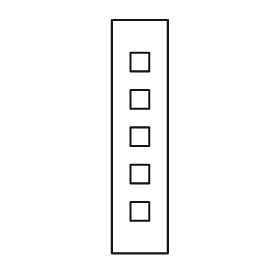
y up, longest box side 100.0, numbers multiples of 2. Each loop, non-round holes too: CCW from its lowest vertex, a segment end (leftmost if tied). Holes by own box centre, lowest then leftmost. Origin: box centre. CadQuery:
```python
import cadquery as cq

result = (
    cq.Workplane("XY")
    .moveTo(-12.0, -50.0)
    .lineTo(12.0, -50.0)
    .lineTo(12.0, 50.0)
    .lineTo(-12.0, 50.0)
    .close()
    .moveTo(-4.0, -36.0)
    .lineTo(4.0, -36.0)
    .lineTo(4.0, -28.0)
    .lineTo(-4.0, -28.0)
    .close()
    .moveTo(-4.0, -20.0)
    .lineTo(4.0, -20.0)
    .lineTo(4.0, -12.0)
    .lineTo(-4.0, -12.0)
    .close()
    .moveTo(-4.0, -4.0)
    .lineTo(4.0, -4.0)
    .lineTo(4.0, 4.0)
    .lineTo(-4.0, 4.0)
    .close()
    .moveTo(-4.0, 12.0)
    .lineTo(4.0, 12.0)
    .lineTo(4.0, 20.0)
    .lineTo(-4.0, 20.0)
    .close()
    .moveTo(-4.0, 28.0)
    .lineTo(4.0, 28.0)
    .lineTo(4.0, 36.0)
    .lineTo(-4.0, 36.0)
    .close()
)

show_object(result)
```